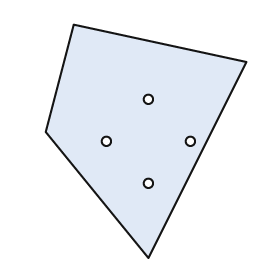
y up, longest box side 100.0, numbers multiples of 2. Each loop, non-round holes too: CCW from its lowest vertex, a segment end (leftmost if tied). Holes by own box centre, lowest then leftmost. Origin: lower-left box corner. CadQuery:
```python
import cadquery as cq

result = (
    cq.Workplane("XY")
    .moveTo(44.0, 0.0)
    .lineTo(86.0, 84.0)
    .lineTo(12.0, 100.0)
    .lineTo(0.0, 54.0)
    .close()
    .moveTo(44.0, 32.0)
    .circle(2.0)
    .moveTo(26.0, 50.0)
    .circle(2.0)
    .moveTo(62.0, 50.0)
    .circle(2.0)
    .moveTo(44.0, 68.0)
    .circle(2.0)
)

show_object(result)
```